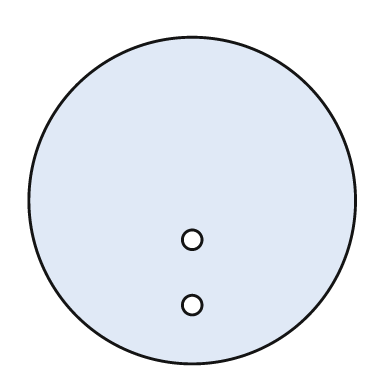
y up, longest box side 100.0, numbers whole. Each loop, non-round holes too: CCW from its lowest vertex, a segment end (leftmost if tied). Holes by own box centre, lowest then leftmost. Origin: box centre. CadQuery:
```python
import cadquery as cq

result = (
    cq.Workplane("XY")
    .moveTo(0.0, 0.0)
    .circle(50.0)
    .moveTo(0.0, -32.0)
    .circle(3.0)
    .moveTo(0.0, -12.0)
    .circle(3.0)
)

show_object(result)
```